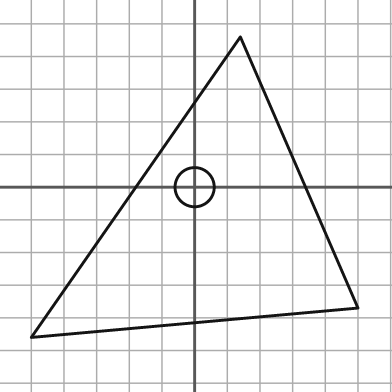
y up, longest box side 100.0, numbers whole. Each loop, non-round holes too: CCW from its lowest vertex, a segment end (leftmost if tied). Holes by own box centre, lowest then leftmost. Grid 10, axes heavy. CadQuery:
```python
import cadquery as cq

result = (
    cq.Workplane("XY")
    .moveTo(-50.0, -46.0)
    .lineTo(50.0, -37.0)
    .lineTo(14.0, 46.0)
    .close()
    .moveTo(0.0, 0.0)
    .circle(6.0)
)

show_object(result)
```